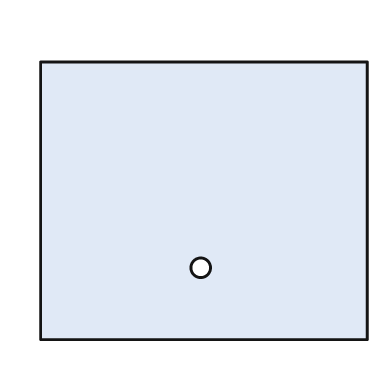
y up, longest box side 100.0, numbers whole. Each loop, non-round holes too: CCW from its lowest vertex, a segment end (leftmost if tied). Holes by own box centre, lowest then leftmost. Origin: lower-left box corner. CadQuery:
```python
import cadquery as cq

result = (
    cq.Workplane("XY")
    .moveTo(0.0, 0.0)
    .lineTo(100.0, 0.0)
    .lineTo(100.0, 85.0)
    .lineTo(0.0, 85.0)
    .close()
    .moveTo(49.0, 22.0)
    .circle(3.0)
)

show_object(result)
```